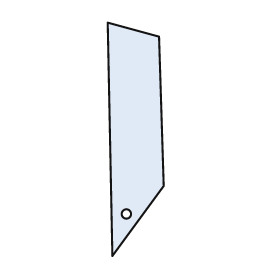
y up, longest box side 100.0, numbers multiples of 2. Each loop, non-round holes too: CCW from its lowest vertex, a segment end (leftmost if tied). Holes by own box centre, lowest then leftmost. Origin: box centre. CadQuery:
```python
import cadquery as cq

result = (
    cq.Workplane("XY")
    .moveTo(-10.0, -50.0)
    .lineTo(12.0, -20.0)
    .lineTo(10.0, 44.0)
    .lineTo(-12.0, 50.0)
    .close()
    .moveTo(-4.0, -32.0)
    .circle(2.0)
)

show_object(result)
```